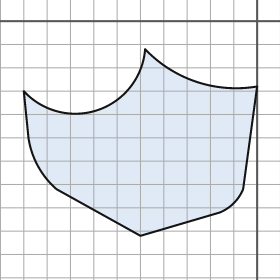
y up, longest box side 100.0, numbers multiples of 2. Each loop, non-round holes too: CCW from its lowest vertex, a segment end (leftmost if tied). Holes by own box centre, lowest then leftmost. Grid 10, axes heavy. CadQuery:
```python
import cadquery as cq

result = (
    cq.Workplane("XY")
    .moveTo(-50.0, -92.0)
    .lineTo(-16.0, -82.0)
    .threePointArc((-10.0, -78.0), (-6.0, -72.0))
    .lineTo(0.0, -28.0)
    .threePointArc((-26.0, -26.0), (-48.0, -12.0))
    .threePointArc((-68.0, -38.0), (-100.0, -30.0))
    .lineTo(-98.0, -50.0)
    .threePointArc((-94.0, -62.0), (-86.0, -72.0))
    .close()
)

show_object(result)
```